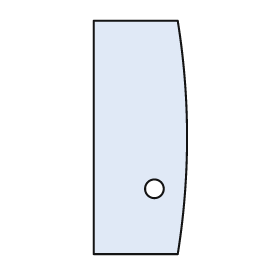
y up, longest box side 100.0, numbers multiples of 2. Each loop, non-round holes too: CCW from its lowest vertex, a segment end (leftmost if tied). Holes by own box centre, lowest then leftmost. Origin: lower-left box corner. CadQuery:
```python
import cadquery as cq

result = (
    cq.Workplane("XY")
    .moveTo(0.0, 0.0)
    .lineTo(36.0, 0.0)
    .threePointArc((40.0, 50.0), (36.0, 100.0))
    .lineTo(0.0, 100.0)
    .close()
    .moveTo(26.0, 28.0)
    .circle(4.0)
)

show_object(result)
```